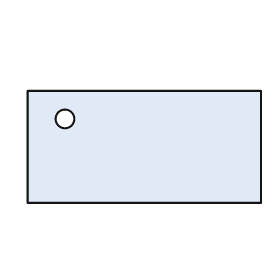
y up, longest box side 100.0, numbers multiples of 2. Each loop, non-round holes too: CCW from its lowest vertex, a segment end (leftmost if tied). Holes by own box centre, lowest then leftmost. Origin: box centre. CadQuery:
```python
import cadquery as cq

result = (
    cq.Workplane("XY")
    .moveTo(-50.0, -24.0)
    .lineTo(50.0, -24.0)
    .lineTo(50.0, 24.0)
    .lineTo(-50.0, 24.0)
    .close()
    .moveTo(-34.0, 12.0)
    .circle(4.0)
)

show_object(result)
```